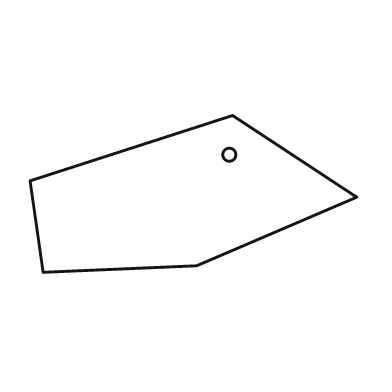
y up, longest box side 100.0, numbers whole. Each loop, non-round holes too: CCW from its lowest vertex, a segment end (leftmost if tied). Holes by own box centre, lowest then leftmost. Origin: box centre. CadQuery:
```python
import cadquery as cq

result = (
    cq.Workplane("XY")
    .moveTo(-46.0, -24.0)
    .lineTo(1.0, -22.0)
    .lineTo(50.0, -1.0)
    .lineTo(12.0, 24.0)
    .lineTo(-50.0, 4.0)
    .close()
    .moveTo(11.0, 12.0)
    .circle(2.0)
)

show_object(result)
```